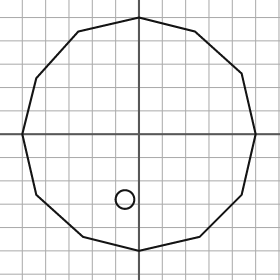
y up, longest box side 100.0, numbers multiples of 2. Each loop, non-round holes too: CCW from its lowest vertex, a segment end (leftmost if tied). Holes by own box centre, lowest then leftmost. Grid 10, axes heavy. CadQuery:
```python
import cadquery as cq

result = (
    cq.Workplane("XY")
    .moveTo(0.0, -50.0)
    .lineTo(26.0, -44.0)
    .lineTo(44.0, -26.0)
    .lineTo(50.0, 0.0)
    .lineTo(44.0, 26.0)
    .lineTo(24.0, 44.0)
    .lineTo(0.0, 50.0)
    .lineTo(-26.0, 44.0)
    .lineTo(-44.0, 24.0)
    .lineTo(-50.0, 0.0)
    .lineTo(-44.0, -26.0)
    .lineTo(-24.0, -44.0)
    .close()
    .moveTo(-6.0, -28.0)
    .circle(4.0)
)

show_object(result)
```